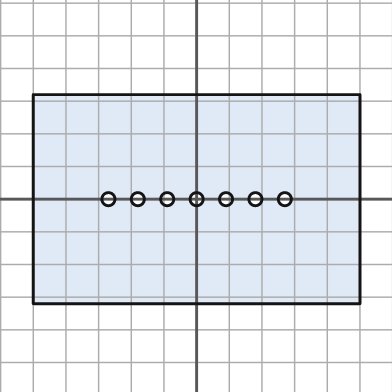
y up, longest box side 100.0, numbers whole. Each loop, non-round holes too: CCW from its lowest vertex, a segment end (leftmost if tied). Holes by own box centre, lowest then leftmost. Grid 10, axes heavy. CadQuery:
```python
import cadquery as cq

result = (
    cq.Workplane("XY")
    .moveTo(-50.0, -32.0)
    .lineTo(50.0, -32.0)
    .lineTo(50.0, 32.0)
    .lineTo(-50.0, 32.0)
    .close()
    .moveTo(-27.0, 0.0)
    .circle(2.0)
    .moveTo(-18.0, 0.0)
    .circle(2.0)
    .moveTo(-9.0, 0.0)
    .circle(2.0)
    .moveTo(0.0, 0.0)
    .circle(2.0)
    .moveTo(9.0, 0.0)
    .circle(2.0)
    .moveTo(18.0, 0.0)
    .circle(2.0)
    .moveTo(27.0, 0.0)
    .circle(2.0)
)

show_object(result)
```